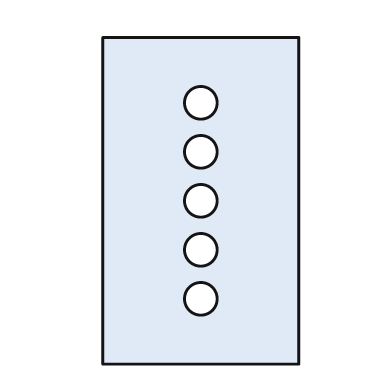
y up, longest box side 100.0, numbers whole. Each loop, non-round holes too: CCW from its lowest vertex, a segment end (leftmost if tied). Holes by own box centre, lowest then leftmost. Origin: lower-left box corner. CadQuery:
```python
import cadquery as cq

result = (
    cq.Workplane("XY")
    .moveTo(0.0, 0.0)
    .lineTo(60.0, 0.0)
    .lineTo(60.0, 100.0)
    .lineTo(0.0, 100.0)
    .close()
    .moveTo(30.0, 20.0)
    .circle(5.0)
    .moveTo(30.0, 35.0)
    .circle(5.0)
    .moveTo(30.0, 50.0)
    .circle(5.0)
    .moveTo(30.0, 65.0)
    .circle(5.0)
    .moveTo(30.0, 80.0)
    .circle(5.0)
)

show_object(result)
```